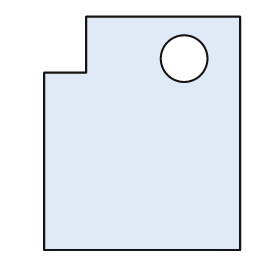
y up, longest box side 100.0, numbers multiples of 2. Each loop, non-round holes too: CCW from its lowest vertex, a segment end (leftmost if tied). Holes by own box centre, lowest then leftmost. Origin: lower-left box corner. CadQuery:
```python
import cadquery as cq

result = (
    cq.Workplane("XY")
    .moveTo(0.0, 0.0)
    .lineTo(84.0, 0.0)
    .lineTo(84.0, 100.0)
    .lineTo(18.0, 100.0)
    .lineTo(18.0, 76.0)
    .lineTo(0.0, 76.0)
    .close()
    .moveTo(60.0, 82.0)
    .circle(10.0)
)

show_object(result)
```